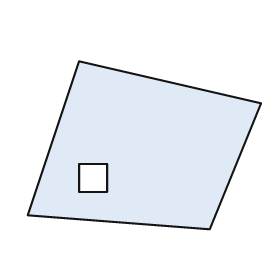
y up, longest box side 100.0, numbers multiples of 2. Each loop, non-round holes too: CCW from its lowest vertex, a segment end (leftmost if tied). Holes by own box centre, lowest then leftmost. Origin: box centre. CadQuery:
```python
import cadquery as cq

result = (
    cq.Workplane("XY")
    .moveTo(28.0, -36.0)
    .lineTo(50.0, 18.0)
    .lineTo(-28.0, 36.0)
    .lineTo(-50.0, -30.0)
    .close()
    .moveTo(-28.0, -20.0)
    .lineTo(-16.0, -20.0)
    .lineTo(-16.0, -8.0)
    .lineTo(-28.0, -8.0)
    .close()
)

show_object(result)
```